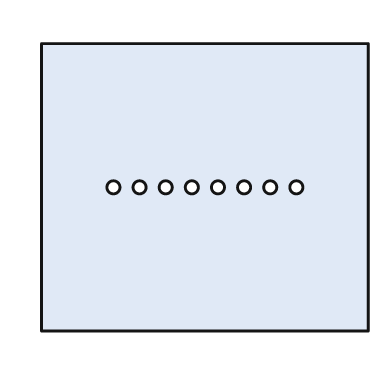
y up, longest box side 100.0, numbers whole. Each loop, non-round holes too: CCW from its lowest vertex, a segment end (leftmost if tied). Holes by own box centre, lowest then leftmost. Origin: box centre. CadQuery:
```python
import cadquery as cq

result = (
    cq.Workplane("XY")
    .moveTo(-50.0, -44.0)
    .lineTo(50.0, -44.0)
    .lineTo(50.0, 44.0)
    .lineTo(-50.0, 44.0)
    .close()
    .moveTo(-28.0, 0.0)
    .circle(2.0)
    .moveTo(-20.0, 0.0)
    .circle(2.0)
    .moveTo(-12.0, 0.0)
    .circle(2.0)
    .moveTo(-4.0, 0.0)
    .circle(2.0)
    .moveTo(4.0, 0.0)
    .circle(2.0)
    .moveTo(12.0, 0.0)
    .circle(2.0)
    .moveTo(20.0, 0.0)
    .circle(2.0)
    .moveTo(28.0, 0.0)
    .circle(2.0)
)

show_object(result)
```